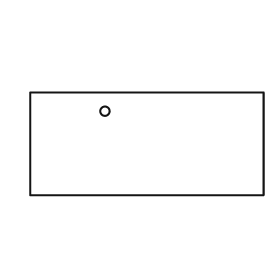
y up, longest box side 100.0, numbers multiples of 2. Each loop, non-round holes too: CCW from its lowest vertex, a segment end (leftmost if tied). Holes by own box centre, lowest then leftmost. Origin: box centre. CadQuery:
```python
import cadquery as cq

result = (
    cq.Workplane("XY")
    .moveTo(-50.0, -22.0)
    .lineTo(50.0, -22.0)
    .lineTo(50.0, 22.0)
    .lineTo(-50.0, 22.0)
    .close()
    .moveTo(-18.0, 14.0)
    .circle(2.0)
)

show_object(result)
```